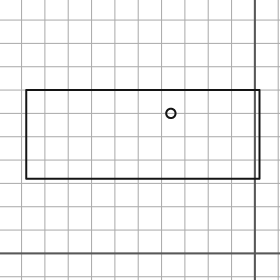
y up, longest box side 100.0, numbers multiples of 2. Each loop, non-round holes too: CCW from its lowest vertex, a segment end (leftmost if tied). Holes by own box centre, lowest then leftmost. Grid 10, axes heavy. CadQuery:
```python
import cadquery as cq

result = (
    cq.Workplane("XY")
    .moveTo(-98.0, 32.0)
    .lineTo(2.0, 32.0)
    .lineTo(2.0, 70.0)
    .lineTo(-98.0, 70.0)
    .close()
    .moveTo(-36.0, 60.0)
    .circle(2.0)
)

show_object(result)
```